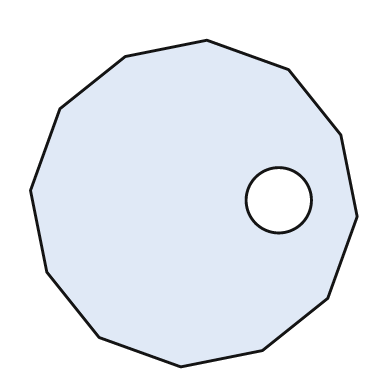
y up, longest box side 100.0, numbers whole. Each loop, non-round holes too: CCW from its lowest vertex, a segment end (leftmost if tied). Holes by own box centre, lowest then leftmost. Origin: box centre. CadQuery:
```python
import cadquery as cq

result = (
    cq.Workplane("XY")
    .moveTo(-4.0, -50.0)
    .lineTo(21.0, -45.0)
    .lineTo(41.0, -29.0)
    .lineTo(50.0, -4.0)
    .lineTo(45.0, 21.0)
    .lineTo(29.0, 41.0)
    .lineTo(4.0, 50.0)
    .lineTo(-21.0, 45.0)
    .lineTo(-41.0, 29.0)
    .lineTo(-50.0, 4.0)
    .lineTo(-45.0, -21.0)
    .lineTo(-29.0, -41.0)
    .close()
    .moveTo(26.0, 1.0)
    .circle(10.0)
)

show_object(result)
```